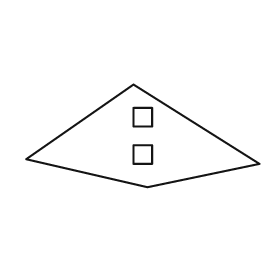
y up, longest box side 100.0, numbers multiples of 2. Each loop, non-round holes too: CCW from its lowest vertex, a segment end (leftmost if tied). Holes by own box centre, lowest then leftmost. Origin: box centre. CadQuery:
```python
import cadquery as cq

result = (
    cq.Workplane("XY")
    .moveTo(2.0, -22.0)
    .lineTo(50.0, -12.0)
    .lineTo(-4.0, 22.0)
    .lineTo(-50.0, -10.0)
    .close()
    .moveTo(-4.0, -12.0)
    .lineTo(4.0, -12.0)
    .lineTo(4.0, -4.0)
    .lineTo(-4.0, -4.0)
    .close()
    .moveTo(-4.0, 4.0)
    .lineTo(4.0, 4.0)
    .lineTo(4.0, 12.0)
    .lineTo(-4.0, 12.0)
    .close()
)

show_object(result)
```